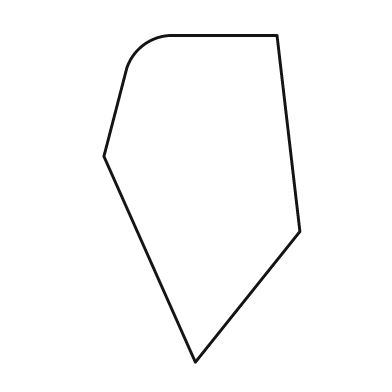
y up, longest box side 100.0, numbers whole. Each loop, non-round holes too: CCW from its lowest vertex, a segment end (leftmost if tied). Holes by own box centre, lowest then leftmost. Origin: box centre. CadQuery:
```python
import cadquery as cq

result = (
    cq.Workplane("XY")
    .moveTo(-2.0, -50.0)
    .lineTo(30.0, -10.0)
    .lineTo(23.0, 50.0)
    .lineTo(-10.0, 50.0)
    .threePointArc((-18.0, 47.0), (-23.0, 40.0))
    .lineTo(-30.0, 13.0)
    .close()
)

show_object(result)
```